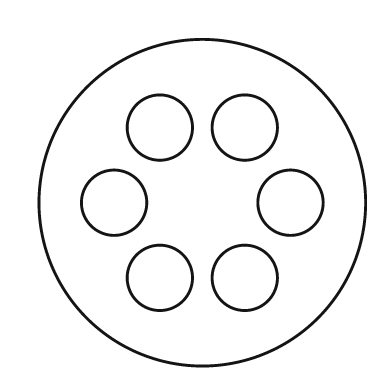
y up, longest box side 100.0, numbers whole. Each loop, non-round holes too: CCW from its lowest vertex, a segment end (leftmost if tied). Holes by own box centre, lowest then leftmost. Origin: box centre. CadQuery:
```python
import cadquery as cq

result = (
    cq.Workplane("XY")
    .moveTo(0.0, 0.0)
    .circle(50.0)
    .moveTo(-13.0, -23.0)
    .circle(10.0)
    .moveTo(13.0, -23.0)
    .circle(10.0)
    .moveTo(-27.0, 0.0)
    .circle(10.0)
    .moveTo(27.0, 0.0)
    .circle(10.0)
    .moveTo(-13.0, 23.0)
    .circle(10.0)
    .moveTo(13.0, 23.0)
    .circle(10.0)
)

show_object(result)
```